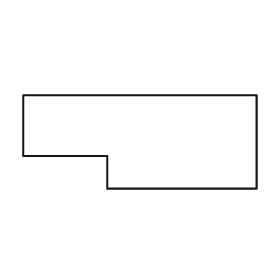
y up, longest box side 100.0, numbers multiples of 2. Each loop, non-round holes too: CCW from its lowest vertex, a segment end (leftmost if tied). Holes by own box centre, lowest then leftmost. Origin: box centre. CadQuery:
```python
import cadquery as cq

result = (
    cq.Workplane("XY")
    .moveTo(-14.0, -20.0)
    .lineTo(50.0, -20.0)
    .lineTo(50.0, 20.0)
    .lineTo(-50.0, 20.0)
    .lineTo(-50.0, -6.0)
    .lineTo(-14.0, -6.0)
    .close()
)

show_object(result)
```